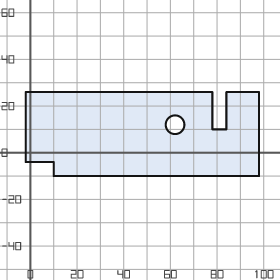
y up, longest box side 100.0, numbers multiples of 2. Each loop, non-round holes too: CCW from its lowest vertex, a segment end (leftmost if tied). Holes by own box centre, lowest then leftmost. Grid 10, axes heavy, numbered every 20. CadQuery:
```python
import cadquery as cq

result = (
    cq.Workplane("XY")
    .moveTo(10.0, -10.0)
    .lineTo(98.0, -10.0)
    .lineTo(98.0, 26.0)
    .lineTo(84.0, 26.0)
    .lineTo(84.0, 10.0)
    .lineTo(78.0, 10.0)
    .lineTo(78.0, 26.0)
    .lineTo(-2.0, 26.0)
    .lineTo(-2.0, -4.0)
    .lineTo(10.0, -4.0)
    .close()
    .moveTo(62.0, 12.0)
    .circle(4.0)
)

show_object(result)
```